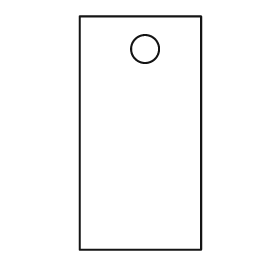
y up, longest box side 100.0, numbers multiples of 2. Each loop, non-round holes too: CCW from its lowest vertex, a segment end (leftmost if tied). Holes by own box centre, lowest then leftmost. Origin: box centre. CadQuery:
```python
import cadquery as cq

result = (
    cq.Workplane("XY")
    .moveTo(-26.0, -50.0)
    .lineTo(26.0, -50.0)
    .lineTo(26.0, 50.0)
    .lineTo(-26.0, 50.0)
    .close()
    .moveTo(2.0, 36.0)
    .circle(6.0)
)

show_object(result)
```